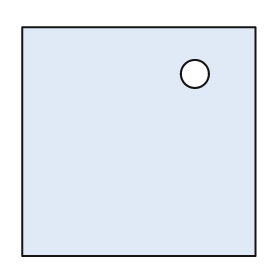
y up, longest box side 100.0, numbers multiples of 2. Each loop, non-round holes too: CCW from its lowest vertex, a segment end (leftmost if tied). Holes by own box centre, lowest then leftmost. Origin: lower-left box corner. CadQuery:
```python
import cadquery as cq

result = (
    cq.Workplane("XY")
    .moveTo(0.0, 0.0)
    .lineTo(100.0, 0.0)
    .lineTo(100.0, 98.0)
    .lineTo(0.0, 98.0)
    .close()
    .moveTo(74.0, 78.0)
    .circle(6.0)
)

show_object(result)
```